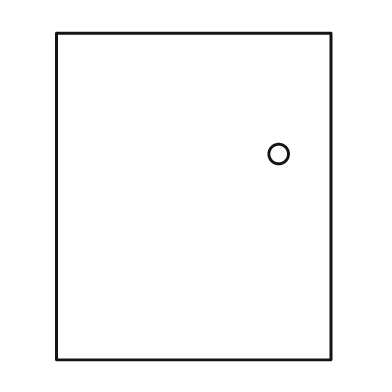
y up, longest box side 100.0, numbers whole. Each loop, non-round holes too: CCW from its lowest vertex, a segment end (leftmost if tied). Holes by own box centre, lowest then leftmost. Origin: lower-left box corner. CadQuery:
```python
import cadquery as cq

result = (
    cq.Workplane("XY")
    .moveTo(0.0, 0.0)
    .lineTo(84.0, 0.0)
    .lineTo(84.0, 100.0)
    .lineTo(0.0, 100.0)
    .close()
    .moveTo(68.0, 63.0)
    .circle(3.0)
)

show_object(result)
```